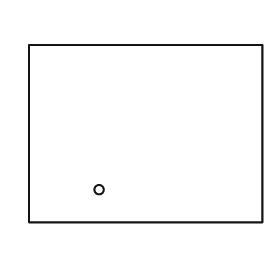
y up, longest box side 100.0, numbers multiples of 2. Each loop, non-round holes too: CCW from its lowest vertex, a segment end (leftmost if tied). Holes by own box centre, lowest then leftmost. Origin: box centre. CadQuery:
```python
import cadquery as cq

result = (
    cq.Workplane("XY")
    .moveTo(-50.0, -38.0)
    .lineTo(50.0, -38.0)
    .lineTo(50.0, 38.0)
    .lineTo(-50.0, 38.0)
    .close()
    .moveTo(-20.0, -24.0)
    .circle(2.0)
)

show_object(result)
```